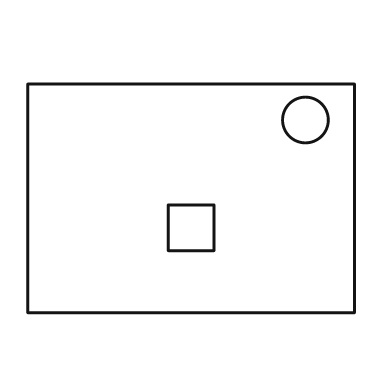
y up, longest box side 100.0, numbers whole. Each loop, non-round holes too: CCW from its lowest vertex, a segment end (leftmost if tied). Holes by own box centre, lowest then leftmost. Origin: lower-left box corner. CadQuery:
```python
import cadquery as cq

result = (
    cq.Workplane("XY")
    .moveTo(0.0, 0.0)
    .lineTo(100.0, 0.0)
    .lineTo(100.0, 70.0)
    .lineTo(0.0, 70.0)
    .close()
    .moveTo(43.0, 19.0)
    .lineTo(57.0, 19.0)
    .lineTo(57.0, 33.0)
    .lineTo(43.0, 33.0)
    .close()
    .moveTo(85.0, 59.0)
    .circle(7.0)
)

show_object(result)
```